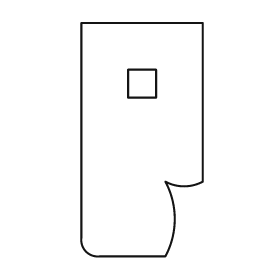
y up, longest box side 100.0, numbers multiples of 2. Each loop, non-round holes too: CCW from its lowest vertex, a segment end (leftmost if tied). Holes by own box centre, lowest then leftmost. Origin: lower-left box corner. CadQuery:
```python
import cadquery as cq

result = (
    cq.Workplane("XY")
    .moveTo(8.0, 0.0)
    .lineTo(36.0, 0.0)
    .threePointArc((40.0, 16.0), (36.0, 32.0))
    .threePointArc((44.0, 30.0), (52.0, 32.0))
    .lineTo(52.0, 100.0)
    .lineTo(0.0, 100.0)
    .lineTo(0.0, 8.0)
    .threePointArc((2.0, 2.0), (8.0, 0.0))
    .close()
    .moveTo(20.0, 68.0)
    .lineTo(32.0, 68.0)
    .lineTo(32.0, 80.0)
    .lineTo(20.0, 80.0)
    .close()
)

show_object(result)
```